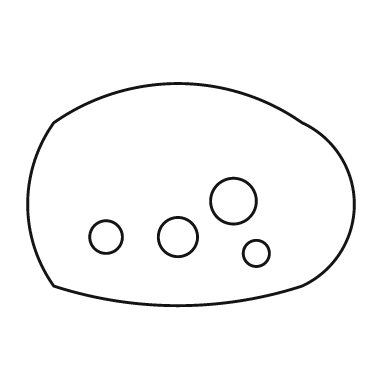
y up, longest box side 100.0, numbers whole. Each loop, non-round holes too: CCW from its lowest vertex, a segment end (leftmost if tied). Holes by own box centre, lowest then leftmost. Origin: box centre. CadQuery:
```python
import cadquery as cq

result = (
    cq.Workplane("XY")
    .moveTo(-42.0, -28.0)
    .threePointArc((-4.0, -34.0), (34.0, -28.0))
    .threePointArc((50.0, -3.0), (34.0, 22.0))
    .threePointArc((-4.0, 34.0), (-42.0, 22.0))
    .threePointArc((-50.0, -3.0), (-42.0, -28.0))
    .close()
    .moveTo(20.0, -18.0)
    .circle(4.0)
    .moveTo(-26.0, -13.0)
    .circle(5.0)
    .moveTo(-4.0, -13.0)
    .circle(6.0)
    .moveTo(13.0, -2.0)
    .circle(7.0)
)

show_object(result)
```